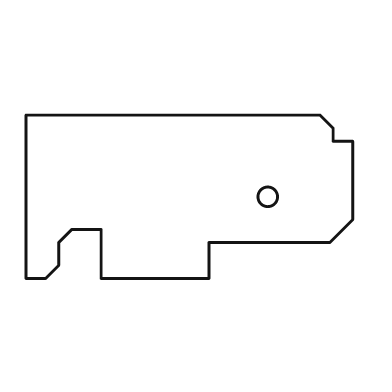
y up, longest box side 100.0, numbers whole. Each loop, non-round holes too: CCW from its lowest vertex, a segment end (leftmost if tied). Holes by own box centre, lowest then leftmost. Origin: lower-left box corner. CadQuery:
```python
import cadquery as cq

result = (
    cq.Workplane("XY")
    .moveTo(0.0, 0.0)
    .lineTo(6.0, 0.0)
    .lineTo(10.0, 4.0)
    .lineTo(10.0, 11.0)
    .lineTo(14.0, 15.0)
    .lineTo(23.0, 15.0)
    .lineTo(23.0, 0.0)
    .lineTo(56.0, 0.0)
    .lineTo(56.0, 11.0)
    .lineTo(93.0, 11.0)
    .lineTo(100.0, 18.0)
    .lineTo(100.0, 42.0)
    .lineTo(94.0, 42.0)
    .lineTo(94.0, 46.0)
    .lineTo(90.0, 50.0)
    .lineTo(0.0, 50.0)
    .close()
    .moveTo(74.0, 25.0)
    .circle(3.0)
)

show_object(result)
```